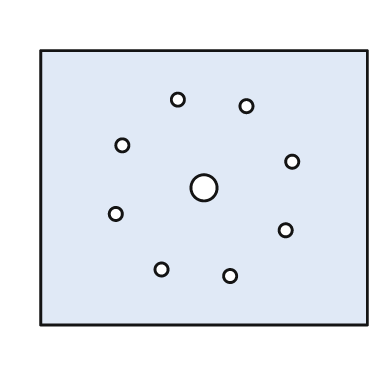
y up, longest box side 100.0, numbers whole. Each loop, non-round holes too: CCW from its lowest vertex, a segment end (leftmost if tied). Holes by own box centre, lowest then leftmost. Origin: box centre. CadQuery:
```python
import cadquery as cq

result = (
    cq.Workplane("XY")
    .moveTo(-50.0, -42.0)
    .lineTo(50.0, -42.0)
    .lineTo(50.0, 42.0)
    .lineTo(-50.0, 42.0)
    .close()
    .moveTo(8.0, -27.0)
    .circle(2.0)
    .moveTo(-13.0, -25.0)
    .circle(2.0)
    .moveTo(25.0, -13.0)
    .circle(2.0)
    .moveTo(-27.0, -8.0)
    .circle(2.0)
    .moveTo(0.0, 0.0)
    .circle(4.0)
    .moveTo(27.0, 8.0)
    .circle(2.0)
    .moveTo(-25.0, 13.0)
    .circle(2.0)
    .moveTo(13.0, 25.0)
    .circle(2.0)
    .moveTo(-8.0, 27.0)
    .circle(2.0)
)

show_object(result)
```